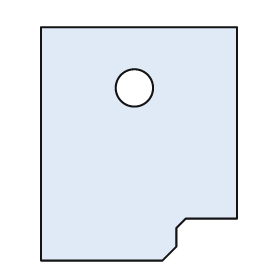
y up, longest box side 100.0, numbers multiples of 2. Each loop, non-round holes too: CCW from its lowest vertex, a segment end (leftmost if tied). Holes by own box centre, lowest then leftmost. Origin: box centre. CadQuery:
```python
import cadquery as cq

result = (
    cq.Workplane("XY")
    .moveTo(-42.0, -50.0)
    .lineTo(10.0, -50.0)
    .lineTo(16.0, -44.0)
    .lineTo(16.0, -36.0)
    .lineTo(20.0, -32.0)
    .lineTo(42.0, -32.0)
    .lineTo(42.0, 50.0)
    .lineTo(-42.0, 50.0)
    .close()
    .moveTo(-2.0, 24.0)
    .circle(8.0)
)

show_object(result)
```